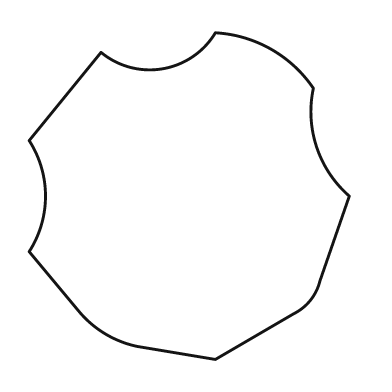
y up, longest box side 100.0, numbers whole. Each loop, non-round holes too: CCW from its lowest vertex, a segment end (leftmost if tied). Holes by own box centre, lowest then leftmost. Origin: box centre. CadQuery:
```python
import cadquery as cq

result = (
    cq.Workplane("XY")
    .moveTo(8.0, -50.0)
    .lineTo(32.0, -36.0)
    .threePointArc((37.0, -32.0), (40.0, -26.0))
    .lineTo(49.0, 0.0)
    .threePointArc((39.0, 15.0), (38.0, 33.0))
    .threePointArc((25.0, 45.0), (8.0, 50.0))
    .threePointArc((-8.0, 39.0), (-27.0, 44.0))
    .lineTo(-49.0, 17.0)
    .threePointArc((-44.0, 0.0), (-49.0, -17.0))
    .lineTo(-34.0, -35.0)
    .threePointArc((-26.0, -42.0), (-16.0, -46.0))
    .close()
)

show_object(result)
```